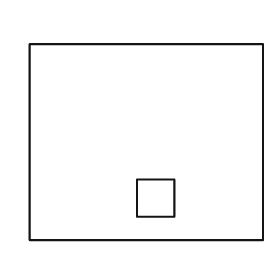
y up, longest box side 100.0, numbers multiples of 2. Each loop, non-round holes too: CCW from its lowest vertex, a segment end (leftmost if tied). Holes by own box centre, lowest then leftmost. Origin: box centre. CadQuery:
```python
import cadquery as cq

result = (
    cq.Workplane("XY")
    .moveTo(-50.0, -42.0)
    .lineTo(50.0, -42.0)
    .lineTo(50.0, 42.0)
    .lineTo(-50.0, 42.0)
    .close()
    .moveTo(-4.0, -32.0)
    .lineTo(12.0, -32.0)
    .lineTo(12.0, -16.0)
    .lineTo(-4.0, -16.0)
    .close()
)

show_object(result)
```